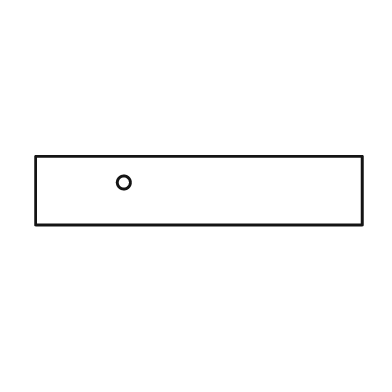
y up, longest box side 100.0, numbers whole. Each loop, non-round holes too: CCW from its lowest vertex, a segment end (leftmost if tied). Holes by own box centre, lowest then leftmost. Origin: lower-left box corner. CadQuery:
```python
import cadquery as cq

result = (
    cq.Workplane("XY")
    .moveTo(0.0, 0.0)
    .lineTo(100.0, 0.0)
    .lineTo(100.0, 21.0)
    .lineTo(0.0, 21.0)
    .close()
    .moveTo(27.0, 13.0)
    .circle(2.0)
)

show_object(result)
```